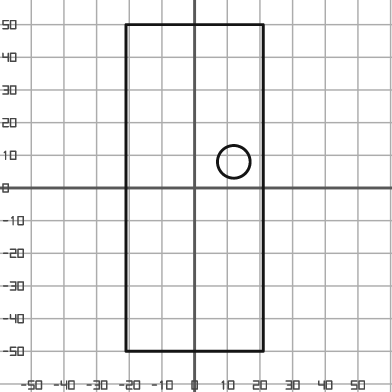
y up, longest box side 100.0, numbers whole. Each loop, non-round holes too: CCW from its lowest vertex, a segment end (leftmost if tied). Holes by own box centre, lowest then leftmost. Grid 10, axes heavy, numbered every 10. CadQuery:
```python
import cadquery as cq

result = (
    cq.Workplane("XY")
    .moveTo(-21.0, -50.0)
    .lineTo(21.0, -50.0)
    .lineTo(21.0, 50.0)
    .lineTo(-21.0, 50.0)
    .close()
    .moveTo(12.0, 8.0)
    .circle(5.0)
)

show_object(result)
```